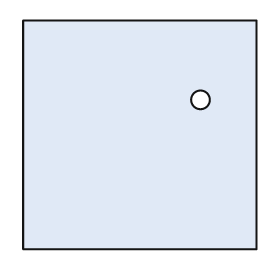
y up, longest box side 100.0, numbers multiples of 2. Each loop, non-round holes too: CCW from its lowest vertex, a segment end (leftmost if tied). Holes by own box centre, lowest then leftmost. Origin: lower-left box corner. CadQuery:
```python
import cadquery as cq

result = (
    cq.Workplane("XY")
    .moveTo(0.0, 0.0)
    .lineTo(100.0, 0.0)
    .lineTo(100.0, 98.0)
    .lineTo(0.0, 98.0)
    .close()
    .moveTo(76.0, 64.0)
    .circle(4.0)
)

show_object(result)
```